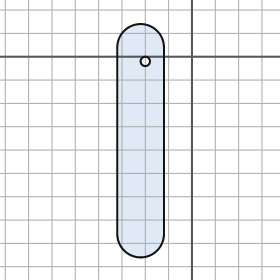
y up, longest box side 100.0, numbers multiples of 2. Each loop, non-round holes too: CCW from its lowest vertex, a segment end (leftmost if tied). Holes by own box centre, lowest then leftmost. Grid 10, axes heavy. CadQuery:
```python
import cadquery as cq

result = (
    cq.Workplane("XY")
    .moveTo(-32.0, -76.0)
    .threePointArc((-22.0, -86.0), (-12.0, -76.0))
    .lineTo(-12.0, 4.0)
    .threePointArc((-22.0, 14.0), (-32.0, 4.0))
    .close()
    .moveTo(-20.0, -2.0)
    .circle(2.0)
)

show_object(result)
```